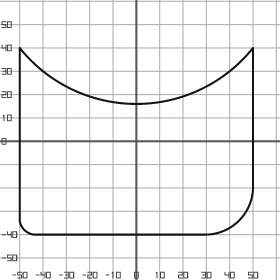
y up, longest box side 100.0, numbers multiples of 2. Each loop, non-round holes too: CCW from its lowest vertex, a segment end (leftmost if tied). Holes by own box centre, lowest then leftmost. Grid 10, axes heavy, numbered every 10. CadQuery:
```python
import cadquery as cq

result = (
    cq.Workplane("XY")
    .moveTo(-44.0, -40.0)
    .lineTo(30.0, -40.0)
    .threePointArc((44.0, -34.0), (50.0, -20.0))
    .lineTo(50.0, 40.0)
    .threePointArc((0.0, 16.0), (-50.0, 40.0))
    .lineTo(-50.0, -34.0)
    .threePointArc((-48.0, -38.0), (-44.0, -40.0))
    .close()
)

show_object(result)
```